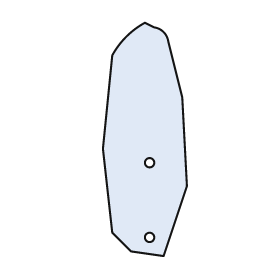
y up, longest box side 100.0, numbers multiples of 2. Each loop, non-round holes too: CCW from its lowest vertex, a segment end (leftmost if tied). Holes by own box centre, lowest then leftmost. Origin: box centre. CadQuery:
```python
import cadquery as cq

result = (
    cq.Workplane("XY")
    .moveTo(8.0, -50.0)
    .lineTo(18.0, -20.0)
    .lineTo(16.0, 18.0)
    .lineTo(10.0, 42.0)
    .threePointArc((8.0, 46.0), (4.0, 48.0))
    .lineTo(0.0, 50.0)
    .threePointArc((-8.0, 44.0), (-14.0, 36.0))
    .lineTo(-18.0, -4.0)
    .lineTo(-14.0, -40.0)
    .lineTo(-6.0, -48.0)
    .close()
    .moveTo(2.0, -42.0)
    .circle(2.0)
    .moveTo(2.0, -10.0)
    .circle(2.0)
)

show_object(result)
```